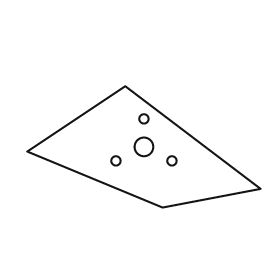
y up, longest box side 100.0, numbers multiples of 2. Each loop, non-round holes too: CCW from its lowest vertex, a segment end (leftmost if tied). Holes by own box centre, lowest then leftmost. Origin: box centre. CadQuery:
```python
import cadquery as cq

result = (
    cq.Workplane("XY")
    .moveTo(8.0, -26.0)
    .lineTo(50.0, -18.0)
    .lineTo(-8.0, 26.0)
    .lineTo(-50.0, -2.0)
    .close()
    .moveTo(-12.0, -6.0)
    .circle(2.0)
    .moveTo(12.0, -6.0)
    .circle(2.0)
    .moveTo(0.0, 0.0)
    .circle(4.0)
    .moveTo(0.0, 12.0)
    .circle(2.0)
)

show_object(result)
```